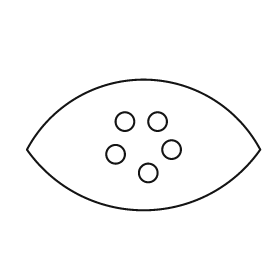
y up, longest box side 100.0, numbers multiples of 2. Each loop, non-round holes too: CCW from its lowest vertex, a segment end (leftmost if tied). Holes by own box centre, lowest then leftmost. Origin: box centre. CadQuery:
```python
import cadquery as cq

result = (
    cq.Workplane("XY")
    .moveTo(-50.0, -2.0)
    .threePointArc((0.0, -28.0), (50.0, -2.0))
    .threePointArc((0.0, 28.0), (-50.0, -2.0))
    .close()
    .moveTo(2.0, -12.0)
    .circle(4.0)
    .moveTo(-12.0, -4.0)
    .circle(4.0)
    .moveTo(12.0, -2.0)
    .circle(4.0)
    .moveTo(-8.0, 10.0)
    .circle(4.0)
    .moveTo(6.0, 10.0)
    .circle(4.0)
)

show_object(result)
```